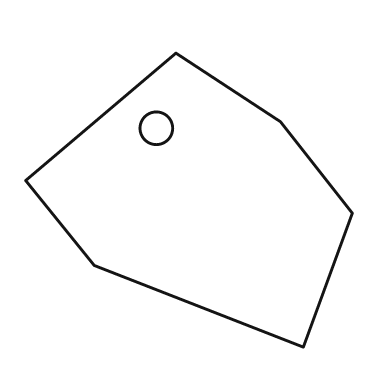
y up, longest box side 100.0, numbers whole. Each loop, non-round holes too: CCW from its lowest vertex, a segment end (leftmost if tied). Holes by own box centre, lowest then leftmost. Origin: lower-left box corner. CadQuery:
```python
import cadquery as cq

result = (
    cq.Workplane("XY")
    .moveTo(85.0, 0.0)
    .lineTo(100.0, 41.0)
    .lineTo(78.0, 69.0)
    .lineTo(46.0, 90.0)
    .lineTo(0.0, 51.0)
    .lineTo(21.0, 25.0)
    .close()
    .moveTo(40.0, 67.0)
    .circle(5.0)
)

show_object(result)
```